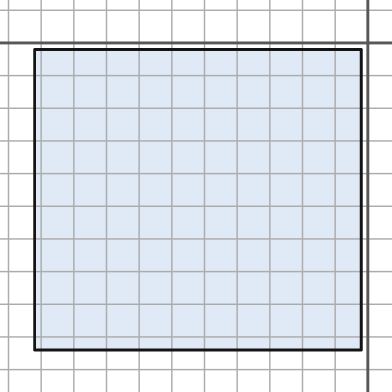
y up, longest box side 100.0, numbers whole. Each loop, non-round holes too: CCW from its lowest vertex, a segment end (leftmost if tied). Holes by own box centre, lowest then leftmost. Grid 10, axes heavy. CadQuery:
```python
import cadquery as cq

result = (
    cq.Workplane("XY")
    .moveTo(-102.0, -94.0)
    .lineTo(-2.0, -94.0)
    .lineTo(-2.0, -2.0)
    .lineTo(-102.0, -2.0)
    .close()
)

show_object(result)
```